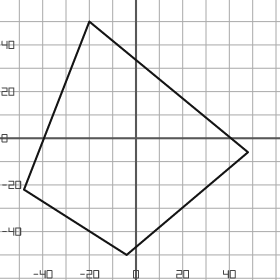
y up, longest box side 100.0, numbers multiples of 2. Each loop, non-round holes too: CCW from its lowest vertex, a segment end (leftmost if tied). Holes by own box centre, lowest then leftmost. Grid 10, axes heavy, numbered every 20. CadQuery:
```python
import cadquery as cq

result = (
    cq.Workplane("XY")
    .moveTo(-4.0, -50.0)
    .lineTo(48.0, -6.0)
    .lineTo(-20.0, 50.0)
    .lineTo(-48.0, -22.0)
    .close()
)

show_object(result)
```